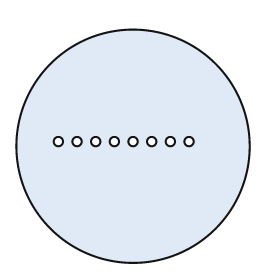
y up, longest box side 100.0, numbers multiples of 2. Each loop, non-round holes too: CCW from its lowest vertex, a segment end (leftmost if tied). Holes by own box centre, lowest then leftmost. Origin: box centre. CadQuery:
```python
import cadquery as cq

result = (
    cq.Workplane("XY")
    .moveTo(0.0, 0.0)
    .circle(50.0)
    .moveTo(-32.0, 2.0)
    .circle(2.0)
    .moveTo(-24.0, 2.0)
    .circle(2.0)
    .moveTo(-16.0, 2.0)
    .circle(2.0)
    .moveTo(-8.0, 2.0)
    .circle(2.0)
    .moveTo(0.0, 2.0)
    .circle(2.0)
    .moveTo(8.0, 2.0)
    .circle(2.0)
    .moveTo(16.0, 2.0)
    .circle(2.0)
    .moveTo(24.0, 2.0)
    .circle(2.0)
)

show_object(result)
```